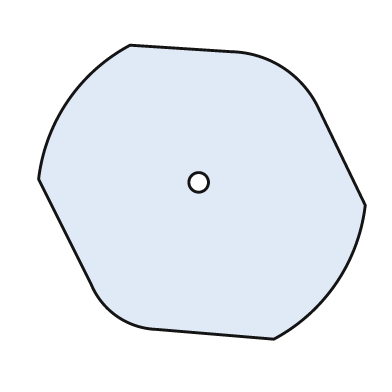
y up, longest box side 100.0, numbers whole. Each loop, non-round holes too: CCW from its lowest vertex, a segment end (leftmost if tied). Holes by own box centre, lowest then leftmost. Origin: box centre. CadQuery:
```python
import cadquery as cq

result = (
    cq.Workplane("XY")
    .moveTo(22.0, -45.0)
    .threePointArc((41.0, -28.0), (50.0, -4.0))
    .lineTo(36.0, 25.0)
    .threePointArc((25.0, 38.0), (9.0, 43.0))
    .lineTo(-22.0, 45.0)
    .threePointArc((-41.0, 28.0), (-50.0, 4.0))
    .lineTo(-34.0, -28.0)
    .threePointArc((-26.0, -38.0), (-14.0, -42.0))
    .close()
    .moveTo(-1.0, 3.0)
    .circle(3.0)
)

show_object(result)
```